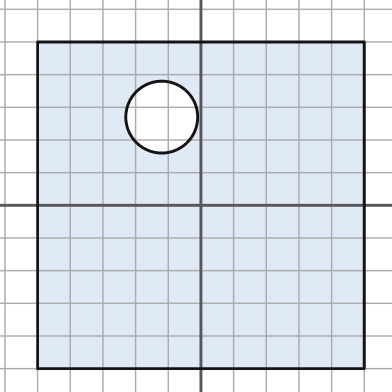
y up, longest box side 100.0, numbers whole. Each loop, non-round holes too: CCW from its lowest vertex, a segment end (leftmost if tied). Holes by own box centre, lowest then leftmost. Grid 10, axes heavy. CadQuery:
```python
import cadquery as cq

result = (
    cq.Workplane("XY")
    .moveTo(-50.0, -50.0)
    .lineTo(50.0, -50.0)
    .lineTo(50.0, 50.0)
    .lineTo(-50.0, 50.0)
    .close()
    .moveTo(-12.0, 27.0)
    .circle(11.0)
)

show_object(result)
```